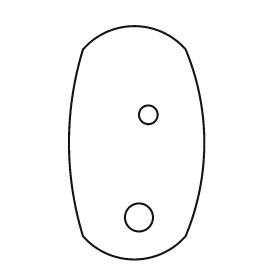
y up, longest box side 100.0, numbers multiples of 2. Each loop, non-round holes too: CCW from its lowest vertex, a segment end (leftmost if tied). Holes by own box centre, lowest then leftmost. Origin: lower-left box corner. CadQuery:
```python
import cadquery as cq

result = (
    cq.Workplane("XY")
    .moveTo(6.0, 10.0)
    .threePointArc((28.0, 0.0), (50.0, 10.0))
    .threePointArc((58.0, 50.0), (50.0, 90.0))
    .threePointArc((28.0, 100.0), (6.0, 90.0))
    .threePointArc((0.0, 50.0), (6.0, 10.0))
    .close()
    .moveTo(30.0, 18.0)
    .circle(6.0)
    .moveTo(34.0, 62.0)
    .circle(4.0)
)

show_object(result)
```